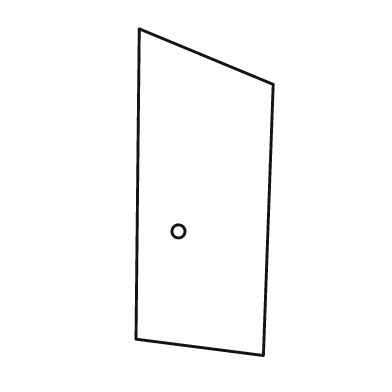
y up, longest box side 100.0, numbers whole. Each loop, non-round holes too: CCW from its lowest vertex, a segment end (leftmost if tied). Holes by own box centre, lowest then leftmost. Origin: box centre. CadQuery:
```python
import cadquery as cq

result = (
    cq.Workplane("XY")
    .moveTo(18.0, -50.0)
    .lineTo(21.0, 33.0)
    .lineTo(-20.0, 50.0)
    .lineTo(-21.0, -45.0)
    .close()
    .moveTo(-8.0, -12.0)
    .circle(2.0)
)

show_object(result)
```